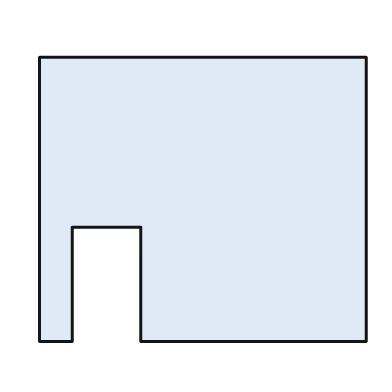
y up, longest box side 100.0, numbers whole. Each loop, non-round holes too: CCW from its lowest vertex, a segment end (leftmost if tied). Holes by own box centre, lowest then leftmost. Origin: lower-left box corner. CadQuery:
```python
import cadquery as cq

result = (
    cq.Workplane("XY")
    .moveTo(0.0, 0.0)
    .lineTo(10.0, 0.0)
    .lineTo(10.0, 35.0)
    .lineTo(31.0, 35.0)
    .lineTo(31.0, 0.0)
    .lineTo(100.0, 0.0)
    .lineTo(100.0, 87.0)
    .lineTo(0.0, 87.0)
    .close()
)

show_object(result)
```